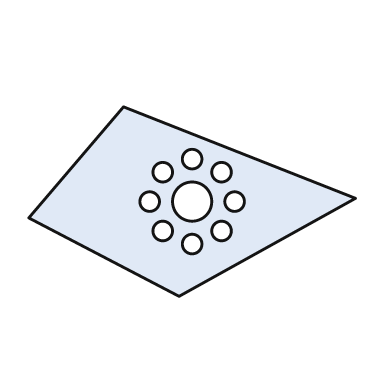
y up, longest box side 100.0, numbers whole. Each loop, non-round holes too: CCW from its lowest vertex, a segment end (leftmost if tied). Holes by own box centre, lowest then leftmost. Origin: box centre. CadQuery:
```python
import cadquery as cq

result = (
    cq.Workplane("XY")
    .moveTo(-4.0, -29.0)
    .lineTo(50.0, 1.0)
    .lineTo(-21.0, 29.0)
    .lineTo(-50.0, -5.0)
    .close()
    .moveTo(0.0, -13.0)
    .circle(3.0)
    .moveTo(-9.0, -9.0)
    .circle(3.0)
    .moveTo(9.0, -9.0)
    .circle(3.0)
    .moveTo(-13.0, 0.0)
    .circle(3.0)
    .moveTo(0.0, 0.0)
    .circle(6.0)
    .moveTo(13.0, 0.0)
    .circle(3.0)
    .moveTo(-9.0, 9.0)
    .circle(3.0)
    .moveTo(9.0, 9.0)
    .circle(3.0)
    .moveTo(0.0, 13.0)
    .circle(3.0)
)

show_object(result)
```